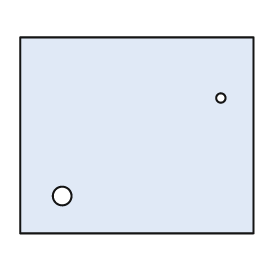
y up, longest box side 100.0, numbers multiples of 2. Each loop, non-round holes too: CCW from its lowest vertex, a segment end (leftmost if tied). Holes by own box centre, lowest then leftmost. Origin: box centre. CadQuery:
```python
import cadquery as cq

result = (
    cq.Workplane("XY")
    .moveTo(-50.0, -42.0)
    .lineTo(50.0, -42.0)
    .lineTo(50.0, 42.0)
    .lineTo(-50.0, 42.0)
    .close()
    .moveTo(-32.0, -26.0)
    .circle(4.0)
    .moveTo(36.0, 16.0)
    .circle(2.0)
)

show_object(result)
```